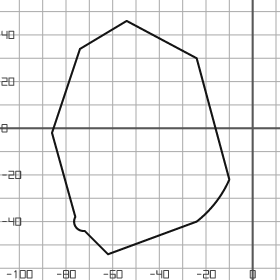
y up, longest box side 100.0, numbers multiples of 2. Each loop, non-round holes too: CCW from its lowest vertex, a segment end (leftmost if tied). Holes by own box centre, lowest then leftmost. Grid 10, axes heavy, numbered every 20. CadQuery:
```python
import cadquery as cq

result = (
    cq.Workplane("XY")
    .moveTo(-62.0, -54.0)
    .lineTo(-24.0, -40.0)
    .threePointArc((-16.0, -32.0), (-10.0, -22.0))
    .lineTo(-24.0, 30.0)
    .lineTo(-54.0, 46.0)
    .lineTo(-74.0, 34.0)
    .lineTo(-86.0, -2.0)
    .lineTo(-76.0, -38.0)
    .threePointArc((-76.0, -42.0), (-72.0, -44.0))
    .close()
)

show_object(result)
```